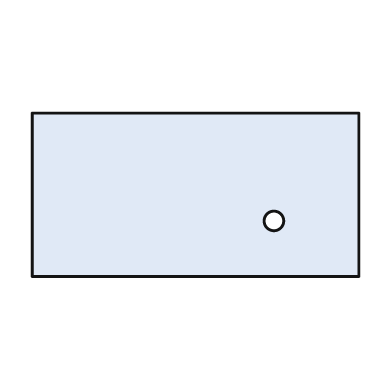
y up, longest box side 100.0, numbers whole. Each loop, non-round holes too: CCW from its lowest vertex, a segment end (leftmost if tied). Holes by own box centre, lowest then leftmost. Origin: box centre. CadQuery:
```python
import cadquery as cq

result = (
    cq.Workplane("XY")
    .moveTo(-50.0, -25.0)
    .lineTo(50.0, -25.0)
    .lineTo(50.0, 25.0)
    .lineTo(-50.0, 25.0)
    .close()
    .moveTo(24.0, -8.0)
    .circle(3.0)
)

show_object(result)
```